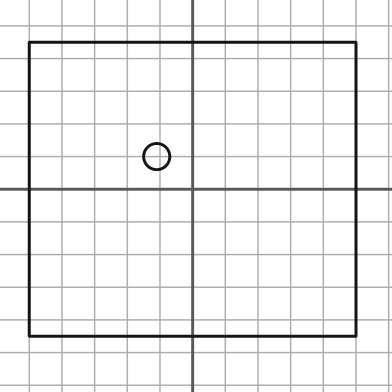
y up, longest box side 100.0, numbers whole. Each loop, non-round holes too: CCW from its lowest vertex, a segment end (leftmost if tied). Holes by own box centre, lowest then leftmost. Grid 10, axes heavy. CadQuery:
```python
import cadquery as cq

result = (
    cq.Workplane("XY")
    .moveTo(-50.0, -45.0)
    .lineTo(50.0, -45.0)
    .lineTo(50.0, 45.0)
    .lineTo(-50.0, 45.0)
    .close()
    .moveTo(-11.0, 10.0)
    .circle(4.0)
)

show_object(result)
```